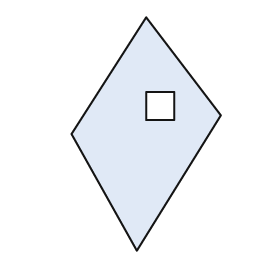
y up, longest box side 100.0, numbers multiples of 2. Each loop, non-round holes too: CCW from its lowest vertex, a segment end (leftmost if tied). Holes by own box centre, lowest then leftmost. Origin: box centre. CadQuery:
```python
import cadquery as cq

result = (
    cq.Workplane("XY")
    .moveTo(-4.0, -50.0)
    .lineTo(32.0, 8.0)
    .lineTo(0.0, 50.0)
    .lineTo(-32.0, 0.0)
    .close()
    .moveTo(0.0, 6.0)
    .lineTo(12.0, 6.0)
    .lineTo(12.0, 18.0)
    .lineTo(0.0, 18.0)
    .close()
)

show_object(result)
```